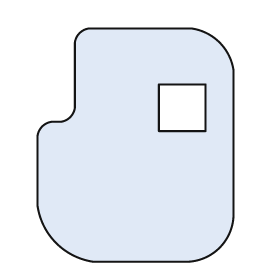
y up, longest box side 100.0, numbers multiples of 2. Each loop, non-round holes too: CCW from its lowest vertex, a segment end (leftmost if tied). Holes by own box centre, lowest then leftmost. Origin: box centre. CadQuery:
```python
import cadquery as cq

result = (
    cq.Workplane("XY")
    .moveTo(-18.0, -50.0)
    .lineTo(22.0, -50.0)
    .threePointArc((36.0, -44.0), (42.0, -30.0))
    .lineTo(42.0, 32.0)
    .threePointArc((36.0, 44.0), (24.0, 50.0))
    .lineTo(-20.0, 50.0)
    .threePointArc((-24.0, 48.0), (-26.0, 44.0))
    .lineTo(-26.0, 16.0)
    .threePointArc((-28.0, 12.0), (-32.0, 10.0))
    .lineTo(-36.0, 10.0)
    .threePointArc((-40.0, 8.0), (-42.0, 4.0))
    .lineTo(-42.0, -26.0)
    .threePointArc((-34.0, -42.0), (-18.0, -50.0))
    .close()
    .moveTo(10.0, 6.0)
    .lineTo(30.0, 6.0)
    .lineTo(30.0, 26.0)
    .lineTo(10.0, 26.0)
    .close()
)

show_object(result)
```